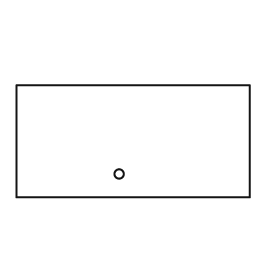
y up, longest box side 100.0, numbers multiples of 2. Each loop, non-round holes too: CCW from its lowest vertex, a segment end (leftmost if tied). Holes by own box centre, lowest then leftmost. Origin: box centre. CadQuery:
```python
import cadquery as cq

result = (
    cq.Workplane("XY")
    .moveTo(-50.0, -24.0)
    .lineTo(50.0, -24.0)
    .lineTo(50.0, 24.0)
    .lineTo(-50.0, 24.0)
    .close()
    .moveTo(-6.0, -14.0)
    .circle(2.0)
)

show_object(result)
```